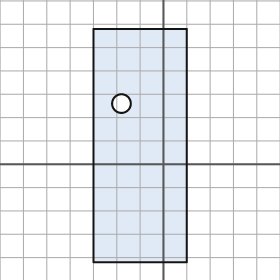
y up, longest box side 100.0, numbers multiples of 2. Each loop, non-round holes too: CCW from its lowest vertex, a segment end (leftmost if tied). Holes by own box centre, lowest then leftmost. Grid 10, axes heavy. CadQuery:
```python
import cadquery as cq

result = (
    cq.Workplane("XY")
    .moveTo(-30.0, -42.0)
    .lineTo(10.0, -42.0)
    .lineTo(10.0, 58.0)
    .lineTo(-30.0, 58.0)
    .close()
    .moveTo(-18.0, 26.0)
    .circle(4.0)
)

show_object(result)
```